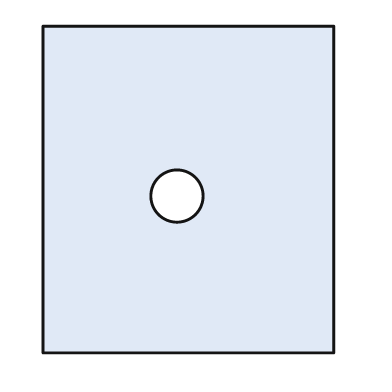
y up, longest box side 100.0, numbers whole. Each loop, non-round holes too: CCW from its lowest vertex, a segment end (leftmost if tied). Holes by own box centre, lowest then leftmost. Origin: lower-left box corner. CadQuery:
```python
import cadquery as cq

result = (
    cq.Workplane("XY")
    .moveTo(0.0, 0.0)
    .lineTo(89.0, 0.0)
    .lineTo(89.0, 100.0)
    .lineTo(0.0, 100.0)
    .close()
    .moveTo(41.0, 48.0)
    .circle(8.0)
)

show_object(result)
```